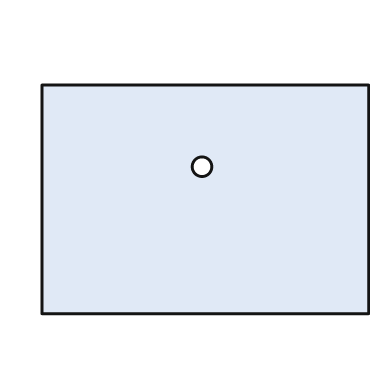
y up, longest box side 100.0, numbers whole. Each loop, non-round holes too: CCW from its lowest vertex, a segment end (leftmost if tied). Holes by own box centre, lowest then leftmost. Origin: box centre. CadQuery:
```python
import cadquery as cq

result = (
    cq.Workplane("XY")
    .moveTo(-50.0, -35.0)
    .lineTo(50.0, -35.0)
    .lineTo(50.0, 35.0)
    .lineTo(-50.0, 35.0)
    .close()
    .moveTo(-1.0, 10.0)
    .circle(3.0)
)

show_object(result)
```